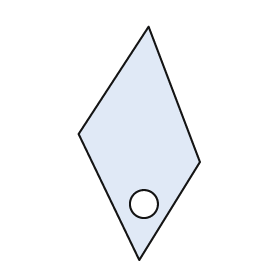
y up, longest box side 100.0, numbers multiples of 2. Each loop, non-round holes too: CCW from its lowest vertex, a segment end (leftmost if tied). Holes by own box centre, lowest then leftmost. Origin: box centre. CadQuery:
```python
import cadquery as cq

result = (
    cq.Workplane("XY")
    .moveTo(0.0, -50.0)
    .lineTo(26.0, -8.0)
    .lineTo(4.0, 50.0)
    .lineTo(-26.0, 4.0)
    .close()
    .moveTo(2.0, -26.0)
    .circle(6.0)
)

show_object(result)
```